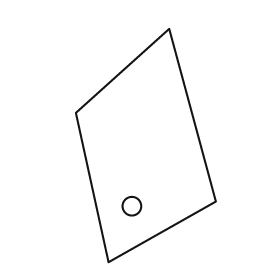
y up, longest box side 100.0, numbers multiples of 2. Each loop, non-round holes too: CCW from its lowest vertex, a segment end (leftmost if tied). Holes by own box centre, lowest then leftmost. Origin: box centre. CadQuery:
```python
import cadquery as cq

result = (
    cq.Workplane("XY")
    .moveTo(-16.0, -50.0)
    .lineTo(30.0, -24.0)
    .lineTo(10.0, 50.0)
    .lineTo(-30.0, 14.0)
    .close()
    .moveTo(-6.0, -26.0)
    .circle(4.0)
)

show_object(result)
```